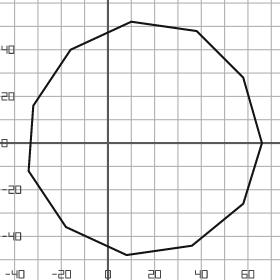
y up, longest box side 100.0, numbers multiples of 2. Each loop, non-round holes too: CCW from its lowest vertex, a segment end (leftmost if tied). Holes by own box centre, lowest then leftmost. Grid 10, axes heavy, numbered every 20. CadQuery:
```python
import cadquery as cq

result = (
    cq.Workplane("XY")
    .moveTo(8.0, -48.0)
    .lineTo(36.0, -44.0)
    .lineTo(58.0, -26.0)
    .lineTo(66.0, 0.0)
    .lineTo(58.0, 28.0)
    .lineTo(38.0, 48.0)
    .lineTo(10.0, 52.0)
    .lineTo(-16.0, 40.0)
    .lineTo(-32.0, 16.0)
    .lineTo(-34.0, -12.0)
    .lineTo(-18.0, -36.0)
    .close()
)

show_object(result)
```